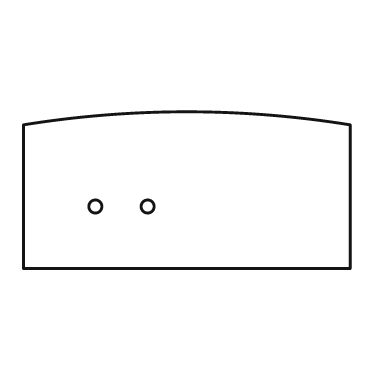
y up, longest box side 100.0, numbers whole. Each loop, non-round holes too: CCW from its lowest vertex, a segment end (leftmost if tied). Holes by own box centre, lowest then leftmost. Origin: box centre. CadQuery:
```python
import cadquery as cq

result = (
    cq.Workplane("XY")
    .moveTo(-50.0, -24.0)
    .lineTo(50.0, -24.0)
    .lineTo(50.0, 20.0)
    .threePointArc((0.0, 24.0), (-50.0, 20.0))
    .close()
    .moveTo(-28.0, -5.0)
    .circle(2.0)
    .moveTo(-12.0, -5.0)
    .circle(2.0)
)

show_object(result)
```